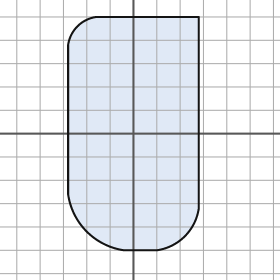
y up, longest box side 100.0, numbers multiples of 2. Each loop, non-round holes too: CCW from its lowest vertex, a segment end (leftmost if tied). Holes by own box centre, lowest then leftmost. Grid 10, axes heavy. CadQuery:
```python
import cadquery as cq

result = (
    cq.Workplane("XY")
    .moveTo(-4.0, -50.0)
    .lineTo(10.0, -50.0)
    .threePointArc((22.0, -44.0), (28.0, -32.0))
    .lineTo(28.0, 50.0)
    .lineTo(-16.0, 50.0)
    .threePointArc((-24.0, 46.0), (-28.0, 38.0))
    .lineTo(-28.0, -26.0)
    .threePointArc((-20.0, -42.0), (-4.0, -50.0))
    .close()
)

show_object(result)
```